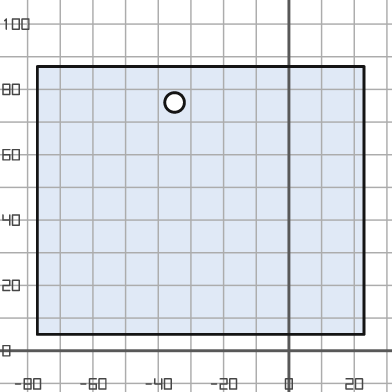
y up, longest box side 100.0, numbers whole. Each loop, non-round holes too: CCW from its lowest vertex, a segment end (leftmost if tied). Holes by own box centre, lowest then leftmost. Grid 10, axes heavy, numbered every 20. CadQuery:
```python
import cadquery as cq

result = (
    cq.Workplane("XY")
    .moveTo(-77.0, 5.0)
    .lineTo(23.0, 5.0)
    .lineTo(23.0, 87.0)
    .lineTo(-77.0, 87.0)
    .close()
    .moveTo(-35.0, 76.0)
    .circle(3.0)
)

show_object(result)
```